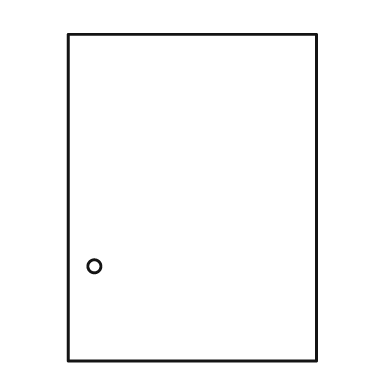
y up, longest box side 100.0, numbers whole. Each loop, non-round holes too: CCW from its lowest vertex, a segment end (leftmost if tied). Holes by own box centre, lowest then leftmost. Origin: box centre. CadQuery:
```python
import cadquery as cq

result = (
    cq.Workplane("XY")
    .moveTo(-38.0, -50.0)
    .lineTo(38.0, -50.0)
    .lineTo(38.0, 50.0)
    .lineTo(-38.0, 50.0)
    .close()
    .moveTo(-30.0, -21.0)
    .circle(2.0)
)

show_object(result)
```